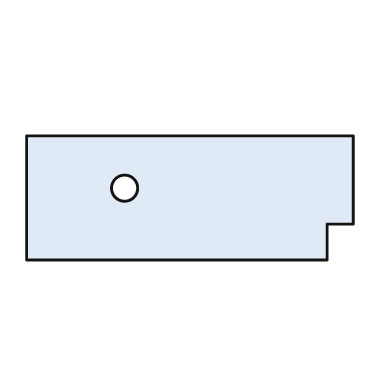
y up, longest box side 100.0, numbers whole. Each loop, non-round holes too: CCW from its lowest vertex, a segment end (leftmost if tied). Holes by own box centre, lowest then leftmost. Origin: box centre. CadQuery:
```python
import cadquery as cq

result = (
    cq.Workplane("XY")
    .moveTo(-50.0, -19.0)
    .lineTo(42.0, -19.0)
    .lineTo(42.0, -8.0)
    .lineTo(50.0, -8.0)
    .lineTo(50.0, 19.0)
    .lineTo(-50.0, 19.0)
    .close()
    .moveTo(-20.0, 3.0)
    .circle(4.0)
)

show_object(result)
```